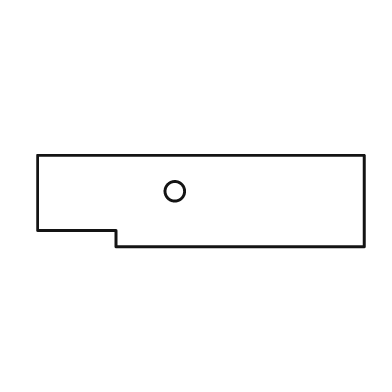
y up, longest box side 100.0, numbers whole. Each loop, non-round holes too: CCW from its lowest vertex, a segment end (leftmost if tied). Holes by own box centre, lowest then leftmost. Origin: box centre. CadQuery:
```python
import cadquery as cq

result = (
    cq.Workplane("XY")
    .moveTo(-26.0, -14.0)
    .lineTo(50.0, -14.0)
    .lineTo(50.0, 14.0)
    .lineTo(-50.0, 14.0)
    .lineTo(-50.0, -9.0)
    .lineTo(-26.0, -9.0)
    .close()
    .moveTo(-8.0, 3.0)
    .circle(3.0)
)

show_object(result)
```